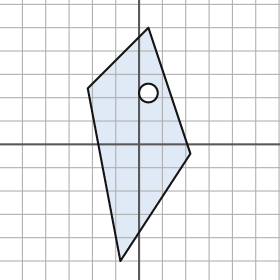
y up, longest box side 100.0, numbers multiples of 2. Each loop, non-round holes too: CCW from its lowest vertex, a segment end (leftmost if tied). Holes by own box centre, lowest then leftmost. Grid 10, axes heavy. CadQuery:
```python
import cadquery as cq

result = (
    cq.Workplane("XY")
    .moveTo(-8.0, -50.0)
    .lineTo(22.0, -4.0)
    .lineTo(4.0, 50.0)
    .lineTo(-22.0, 24.0)
    .close()
    .moveTo(4.0, 22.0)
    .circle(4.0)
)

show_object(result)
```